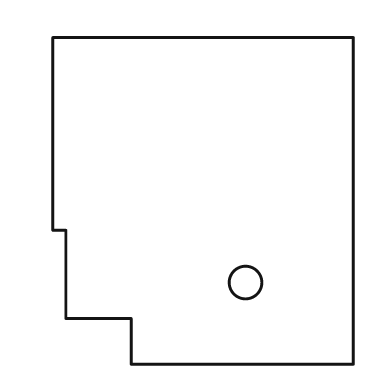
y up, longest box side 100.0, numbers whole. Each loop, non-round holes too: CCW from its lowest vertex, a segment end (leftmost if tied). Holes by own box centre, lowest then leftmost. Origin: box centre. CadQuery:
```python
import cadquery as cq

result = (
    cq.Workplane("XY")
    .moveTo(-22.0, -50.0)
    .lineTo(46.0, -50.0)
    .lineTo(46.0, 50.0)
    .lineTo(-46.0, 50.0)
    .lineTo(-46.0, -9.0)
    .lineTo(-42.0, -9.0)
    .lineTo(-42.0, -36.0)
    .lineTo(-22.0, -36.0)
    .close()
    .moveTo(13.0, -25.0)
    .circle(5.0)
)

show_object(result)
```